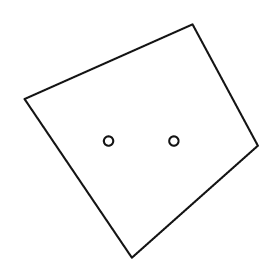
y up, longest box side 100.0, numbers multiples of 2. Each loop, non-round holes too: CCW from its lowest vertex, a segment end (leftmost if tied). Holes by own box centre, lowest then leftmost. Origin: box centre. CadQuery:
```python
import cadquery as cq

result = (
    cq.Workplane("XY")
    .moveTo(-4.0, -50.0)
    .lineTo(50.0, -2.0)
    .lineTo(22.0, 50.0)
    .lineTo(-50.0, 18.0)
    .close()
    .moveTo(-14.0, 0.0)
    .circle(2.0)
    .moveTo(14.0, 0.0)
    .circle(2.0)
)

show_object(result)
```